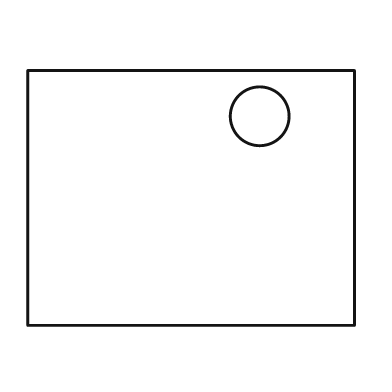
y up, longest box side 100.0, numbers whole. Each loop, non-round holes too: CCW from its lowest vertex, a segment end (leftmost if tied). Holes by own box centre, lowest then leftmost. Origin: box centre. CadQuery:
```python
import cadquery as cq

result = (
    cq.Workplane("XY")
    .moveTo(-50.0, -39.0)
    .lineTo(50.0, -39.0)
    .lineTo(50.0, 39.0)
    .lineTo(-50.0, 39.0)
    .close()
    .moveTo(21.0, 25.0)
    .circle(9.0)
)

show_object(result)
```